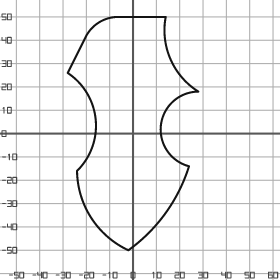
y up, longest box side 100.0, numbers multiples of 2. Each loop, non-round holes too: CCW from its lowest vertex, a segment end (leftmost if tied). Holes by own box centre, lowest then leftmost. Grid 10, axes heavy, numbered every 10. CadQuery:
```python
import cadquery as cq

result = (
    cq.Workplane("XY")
    .moveTo(-2.0, -50.0)
    .threePointArc((14.0, -34.0), (24.0, -14.0))
    .threePointArc((12.0, 4.0), (28.0, 18.0))
    .threePointArc((16.0, 32.0), (14.0, 50.0))
    .lineTo(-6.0, 50.0)
    .threePointArc((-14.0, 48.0), (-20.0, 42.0))
    .lineTo(-28.0, 26.0)
    .threePointArc((-16.0, 6.0), (-24.0, -16.0))
    .threePointArc((-18.0, -36.0), (-2.0, -50.0))
    .close()
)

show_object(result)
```